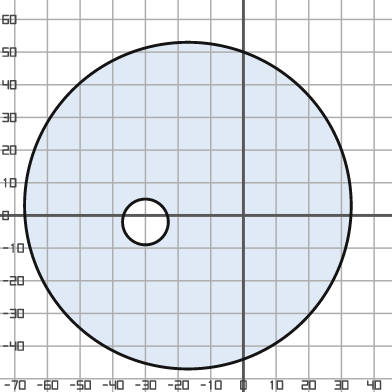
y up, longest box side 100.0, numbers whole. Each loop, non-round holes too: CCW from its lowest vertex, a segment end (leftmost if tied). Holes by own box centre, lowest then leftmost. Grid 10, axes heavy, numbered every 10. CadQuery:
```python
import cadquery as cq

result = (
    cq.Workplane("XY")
    .moveTo(-17.0, 3.0)
    .circle(50.0)
    .moveTo(-30.0, -2.0)
    .circle(7.0)
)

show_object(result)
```